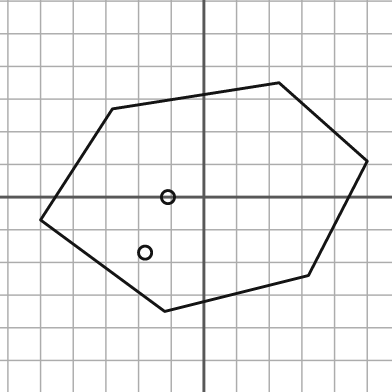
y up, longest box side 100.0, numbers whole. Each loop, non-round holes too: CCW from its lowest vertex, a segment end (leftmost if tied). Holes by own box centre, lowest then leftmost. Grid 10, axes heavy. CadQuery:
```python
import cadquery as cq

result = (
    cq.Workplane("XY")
    .moveTo(-12.0, -35.0)
    .lineTo(32.0, -24.0)
    .lineTo(50.0, 11.0)
    .lineTo(23.0, 35.0)
    .lineTo(-28.0, 27.0)
    .lineTo(-50.0, -7.0)
    .close()
    .moveTo(-18.0, -17.0)
    .circle(2.0)
    .moveTo(-11.0, 0.0)
    .circle(2.0)
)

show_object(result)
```